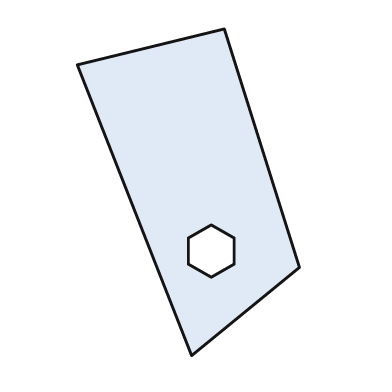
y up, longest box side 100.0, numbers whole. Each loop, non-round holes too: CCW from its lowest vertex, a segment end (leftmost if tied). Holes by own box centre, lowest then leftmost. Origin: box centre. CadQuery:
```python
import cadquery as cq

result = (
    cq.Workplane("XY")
    .moveTo(1.0, -50.0)
    .lineTo(34.0, -23.0)
    .lineTo(11.0, 50.0)
    .lineTo(-34.0, 39.0)
    .close()
    .moveTo(7.0, -26.0)
    .lineTo(14.0, -22.0)
    .lineTo(14.0, -14.0)
    .lineTo(7.0, -10.0)
    .lineTo(0.0, -14.0)
    .lineTo(0.0, -22.0)
    .close()
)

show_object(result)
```